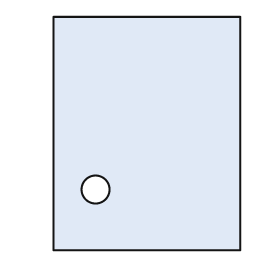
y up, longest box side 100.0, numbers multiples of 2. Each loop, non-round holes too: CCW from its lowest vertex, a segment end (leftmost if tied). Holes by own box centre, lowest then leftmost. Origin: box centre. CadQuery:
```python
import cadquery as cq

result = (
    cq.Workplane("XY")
    .moveTo(-40.0, -50.0)
    .lineTo(40.0, -50.0)
    .lineTo(40.0, 50.0)
    .lineTo(-40.0, 50.0)
    .close()
    .moveTo(-22.0, -24.0)
    .circle(6.0)
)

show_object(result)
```